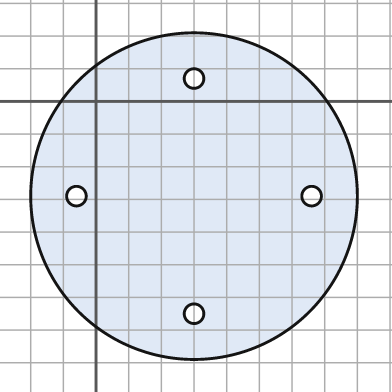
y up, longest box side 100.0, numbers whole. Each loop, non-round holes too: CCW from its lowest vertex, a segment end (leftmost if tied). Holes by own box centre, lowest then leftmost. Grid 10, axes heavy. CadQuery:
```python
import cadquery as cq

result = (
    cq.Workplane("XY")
    .moveTo(30.0, -29.0)
    .circle(50.0)
    .moveTo(30.0, -65.0)
    .circle(3.0)
    .moveTo(-6.0, -29.0)
    .circle(3.0)
    .moveTo(66.0, -29.0)
    .circle(3.0)
    .moveTo(30.0, 7.0)
    .circle(3.0)
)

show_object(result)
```